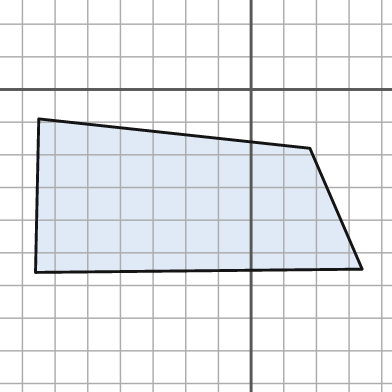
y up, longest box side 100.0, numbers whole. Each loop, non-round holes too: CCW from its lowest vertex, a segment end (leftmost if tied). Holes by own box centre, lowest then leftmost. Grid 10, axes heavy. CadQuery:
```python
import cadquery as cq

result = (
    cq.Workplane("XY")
    .moveTo(-66.0, -56.0)
    .lineTo(34.0, -55.0)
    .lineTo(18.0, -18.0)
    .lineTo(-65.0, -9.0)
    .close()
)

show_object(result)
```